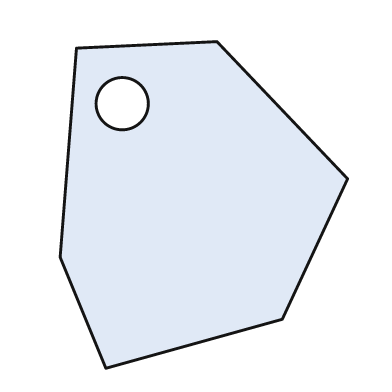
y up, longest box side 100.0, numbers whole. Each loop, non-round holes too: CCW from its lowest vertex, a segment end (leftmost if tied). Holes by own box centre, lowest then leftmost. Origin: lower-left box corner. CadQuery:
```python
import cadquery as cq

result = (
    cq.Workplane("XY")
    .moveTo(14.0, 0.0)
    .lineTo(68.0, 15.0)
    .lineTo(88.0, 58.0)
    .lineTo(48.0, 100.0)
    .lineTo(5.0, 98.0)
    .lineTo(0.0, 34.0)
    .close()
    .moveTo(19.0, 81.0)
    .circle(8.0)
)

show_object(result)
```